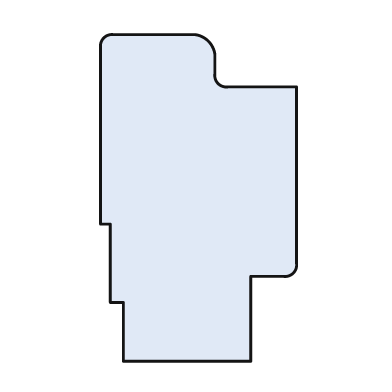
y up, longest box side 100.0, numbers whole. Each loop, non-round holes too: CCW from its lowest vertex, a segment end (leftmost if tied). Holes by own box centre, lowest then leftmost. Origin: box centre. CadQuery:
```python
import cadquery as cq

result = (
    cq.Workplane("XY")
    .moveTo(-23.0, -50.0)
    .lineTo(16.0, -50.0)
    .lineTo(16.0, -24.0)
    .lineTo(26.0, -24.0)
    .threePointArc((29.0, -23.0), (30.0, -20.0))
    .lineTo(30.0, 34.0)
    .lineTo(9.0, 34.0)
    .threePointArc((6.0, 35.0), (5.0, 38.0))
    .lineTo(5.0, 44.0)
    .threePointArc((3.0, 48.0), (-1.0, 50.0))
    .lineTo(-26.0, 50.0)
    .threePointArc((-29.0, 49.0), (-30.0, 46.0))
    .lineTo(-30.0, -8.0)
    .lineTo(-27.0, -8.0)
    .lineTo(-27.0, -32.0)
    .lineTo(-23.0, -32.0)
    .close()
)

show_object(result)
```